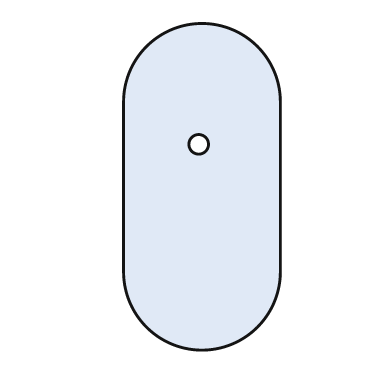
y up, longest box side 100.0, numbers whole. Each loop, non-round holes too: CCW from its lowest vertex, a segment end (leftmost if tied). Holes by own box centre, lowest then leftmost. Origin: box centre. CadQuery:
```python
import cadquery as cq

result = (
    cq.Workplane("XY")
    .moveTo(-24.0, -26.0)
    .threePointArc((0.0, -50.0), (24.0, -26.0))
    .lineTo(24.0, 26.0)
    .threePointArc((0.0, 50.0), (-24.0, 26.0))
    .close()
    .moveTo(-1.0, 13.0)
    .circle(3.0)
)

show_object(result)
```